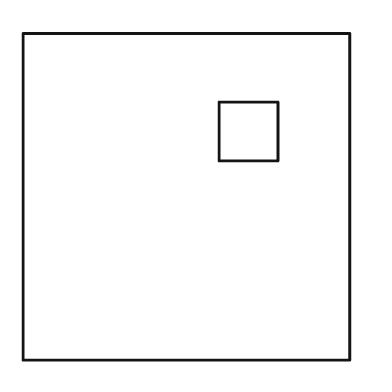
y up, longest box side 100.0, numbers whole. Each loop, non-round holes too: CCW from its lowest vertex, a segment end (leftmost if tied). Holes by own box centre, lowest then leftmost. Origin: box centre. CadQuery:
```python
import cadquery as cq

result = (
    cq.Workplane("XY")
    .moveTo(-50.0, -50.0)
    .lineTo(50.0, -50.0)
    .lineTo(50.0, 50.0)
    .lineTo(-50.0, 50.0)
    .close()
    .moveTo(10.0, 11.0)
    .lineTo(28.0, 11.0)
    .lineTo(28.0, 29.0)
    .lineTo(10.0, 29.0)
    .close()
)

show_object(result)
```